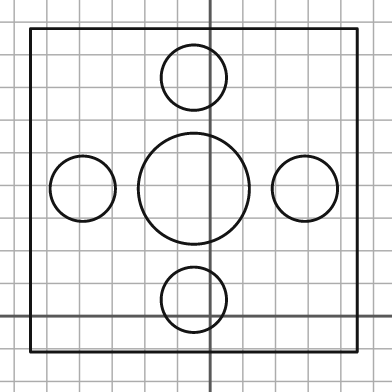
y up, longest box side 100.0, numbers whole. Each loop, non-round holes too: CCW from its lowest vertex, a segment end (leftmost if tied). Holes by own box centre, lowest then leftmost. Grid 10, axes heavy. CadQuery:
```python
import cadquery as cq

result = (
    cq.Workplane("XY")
    .moveTo(-55.0, -11.0)
    .lineTo(45.0, -11.0)
    .lineTo(45.0, 88.0)
    .lineTo(-55.0, 88.0)
    .close()
    .moveTo(-5.0, 5.0)
    .circle(10.0)
    .moveTo(-39.0, 39.0)
    .circle(10.0)
    .moveTo(-5.0, 39.0)
    .circle(17.0)
    .moveTo(29.0, 39.0)
    .circle(10.0)
    .moveTo(-5.0, 73.0)
    .circle(10.0)
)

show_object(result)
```